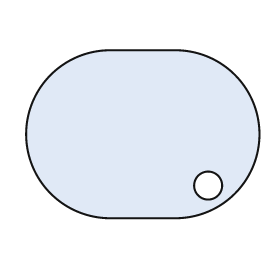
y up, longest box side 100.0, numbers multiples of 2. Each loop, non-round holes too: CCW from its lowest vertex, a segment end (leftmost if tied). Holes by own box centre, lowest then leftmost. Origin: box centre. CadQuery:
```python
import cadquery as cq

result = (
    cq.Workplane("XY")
    .moveTo(-14.0, -36.0)
    .lineTo(14.0, -36.0)
    .threePointArc((50.0, 0.0), (14.0, 36.0))
    .lineTo(-14.0, 36.0)
    .threePointArc((-50.0, 0.0), (-14.0, -36.0))
    .close()
    .moveTo(28.0, -22.0)
    .circle(6.0)
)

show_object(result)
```